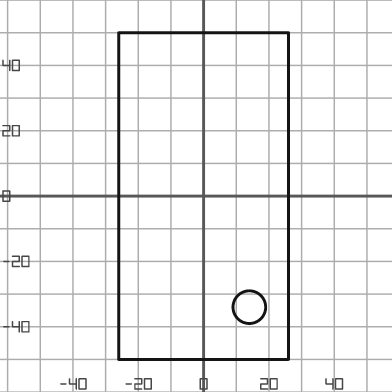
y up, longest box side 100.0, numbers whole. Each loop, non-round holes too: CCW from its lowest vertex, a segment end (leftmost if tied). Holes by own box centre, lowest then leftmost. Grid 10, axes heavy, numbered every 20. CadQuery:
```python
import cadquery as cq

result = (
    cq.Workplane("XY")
    .moveTo(-26.0, -50.0)
    .lineTo(26.0, -50.0)
    .lineTo(26.0, 50.0)
    .lineTo(-26.0, 50.0)
    .close()
    .moveTo(14.0, -34.0)
    .circle(5.0)
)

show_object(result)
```